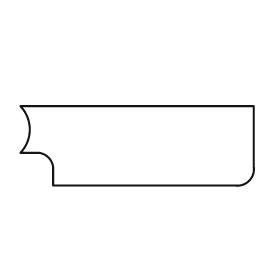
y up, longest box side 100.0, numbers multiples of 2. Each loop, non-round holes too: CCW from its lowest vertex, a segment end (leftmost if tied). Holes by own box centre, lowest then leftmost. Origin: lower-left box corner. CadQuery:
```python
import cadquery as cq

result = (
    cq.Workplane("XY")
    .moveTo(14.0, 0.0)
    .lineTo(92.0, 0.0)
    .threePointArc((98.0, 2.0), (100.0, 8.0))
    .lineTo(100.0, 34.0)
    .lineTo(0.0, 34.0)
    .threePointArc((4.0, 24.0), (0.0, 14.0))
    .lineTo(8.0, 14.0)
    .threePointArc((12.0, 12.0), (14.0, 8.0))
    .close()
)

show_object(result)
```